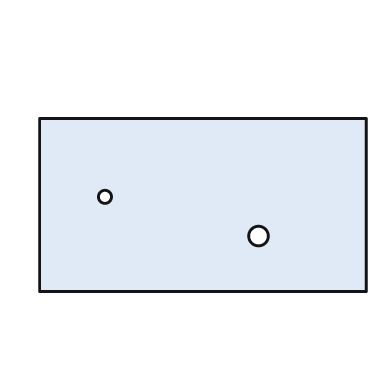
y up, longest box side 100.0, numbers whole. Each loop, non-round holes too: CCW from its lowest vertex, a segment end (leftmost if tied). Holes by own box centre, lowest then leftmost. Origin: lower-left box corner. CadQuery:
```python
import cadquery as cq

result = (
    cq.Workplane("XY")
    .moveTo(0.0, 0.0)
    .lineTo(100.0, 0.0)
    .lineTo(100.0, 53.0)
    .lineTo(0.0, 53.0)
    .close()
    .moveTo(67.0, 17.0)
    .circle(3.0)
    .moveTo(20.0, 29.0)
    .circle(2.0)
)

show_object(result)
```